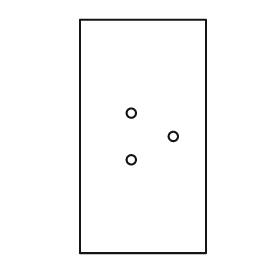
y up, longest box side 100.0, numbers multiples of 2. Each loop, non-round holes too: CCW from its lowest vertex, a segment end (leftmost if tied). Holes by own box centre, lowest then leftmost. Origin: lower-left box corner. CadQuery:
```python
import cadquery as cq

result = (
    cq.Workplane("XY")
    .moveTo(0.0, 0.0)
    .lineTo(54.0, 0.0)
    .lineTo(54.0, 100.0)
    .lineTo(0.0, 100.0)
    .close()
    .moveTo(22.0, 40.0)
    .circle(2.0)
    .moveTo(40.0, 50.0)
    .circle(2.0)
    .moveTo(22.0, 60.0)
    .circle(2.0)
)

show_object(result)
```